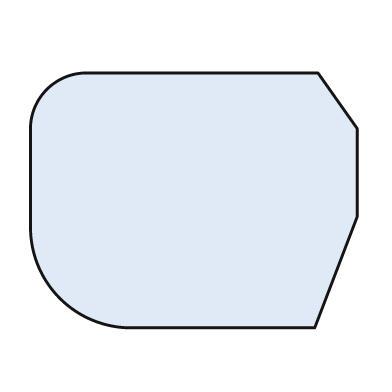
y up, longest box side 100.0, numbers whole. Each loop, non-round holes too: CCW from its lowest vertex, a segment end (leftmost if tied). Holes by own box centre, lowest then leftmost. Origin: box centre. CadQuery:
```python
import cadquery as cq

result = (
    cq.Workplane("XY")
    .moveTo(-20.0, -39.0)
    .lineTo(37.0, -39.0)
    .lineTo(50.0, -5.0)
    .lineTo(50.0, 22.0)
    .lineTo(38.0, 39.0)
    .lineTo(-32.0, 39.0)
    .threePointArc((-45.0, 34.0), (-50.0, 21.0))
    .lineTo(-50.0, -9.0)
    .threePointArc((-41.0, -30.0), (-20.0, -39.0))
    .close()
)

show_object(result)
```